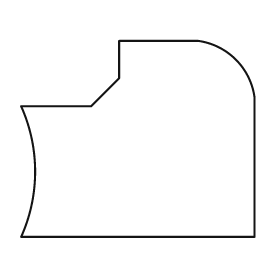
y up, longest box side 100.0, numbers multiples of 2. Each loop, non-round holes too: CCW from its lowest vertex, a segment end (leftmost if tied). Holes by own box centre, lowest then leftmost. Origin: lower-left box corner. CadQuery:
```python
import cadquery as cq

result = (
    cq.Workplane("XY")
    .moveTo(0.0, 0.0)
    .lineTo(100.0, 0.0)
    .lineTo(100.0, 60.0)
    .threePointArc((92.0, 76.0), (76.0, 84.0))
    .lineTo(42.0, 84.0)
    .lineTo(42.0, 68.0)
    .lineTo(30.0, 56.0)
    .lineTo(0.0, 56.0)
    .threePointArc((6.0, 28.0), (0.0, 0.0))
    .close()
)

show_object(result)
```